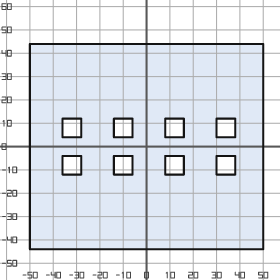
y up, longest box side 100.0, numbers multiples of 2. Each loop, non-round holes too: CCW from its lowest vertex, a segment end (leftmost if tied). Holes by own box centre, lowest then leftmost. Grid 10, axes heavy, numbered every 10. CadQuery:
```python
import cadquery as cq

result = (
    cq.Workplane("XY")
    .moveTo(-50.0, -44.0)
    .lineTo(50.0, -44.0)
    .lineTo(50.0, 44.0)
    .lineTo(-50.0, 44.0)
    .close()
    .moveTo(-36.0, -12.0)
    .lineTo(-28.0, -12.0)
    .lineTo(-28.0, -4.0)
    .lineTo(-36.0, -4.0)
    .close()
    .moveTo(-14.0, -12.0)
    .lineTo(-6.0, -12.0)
    .lineTo(-6.0, -4.0)
    .lineTo(-14.0, -4.0)
    .close()
    .moveTo(8.0, -12.0)
    .lineTo(16.0, -12.0)
    .lineTo(16.0, -4.0)
    .lineTo(8.0, -4.0)
    .close()
    .moveTo(30.0, -12.0)
    .lineTo(38.0, -12.0)
    .lineTo(38.0, -4.0)
    .lineTo(30.0, -4.0)
    .close()
    .moveTo(-36.0, 4.0)
    .lineTo(-28.0, 4.0)
    .lineTo(-28.0, 12.0)
    .lineTo(-36.0, 12.0)
    .close()
    .moveTo(-14.0, 4.0)
    .lineTo(-6.0, 4.0)
    .lineTo(-6.0, 12.0)
    .lineTo(-14.0, 12.0)
    .close()
    .moveTo(8.0, 4.0)
    .lineTo(16.0, 4.0)
    .lineTo(16.0, 12.0)
    .lineTo(8.0, 12.0)
    .close()
    .moveTo(30.0, 4.0)
    .lineTo(38.0, 4.0)
    .lineTo(38.0, 12.0)
    .lineTo(30.0, 12.0)
    .close()
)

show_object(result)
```